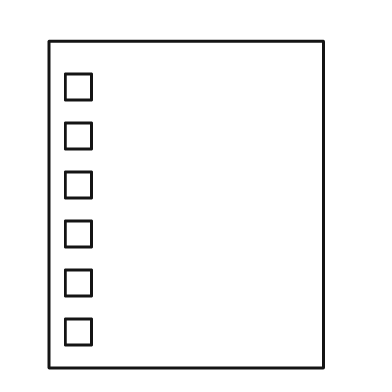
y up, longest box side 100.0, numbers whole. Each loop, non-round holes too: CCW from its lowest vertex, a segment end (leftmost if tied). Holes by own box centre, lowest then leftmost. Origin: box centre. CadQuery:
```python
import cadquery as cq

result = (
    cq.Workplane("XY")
    .moveTo(-42.0, -50.0)
    .lineTo(42.0, -50.0)
    .lineTo(42.0, 50.0)
    .lineTo(-42.0, 50.0)
    .close()
    .moveTo(-37.0, -43.0)
    .lineTo(-29.0, -43.0)
    .lineTo(-29.0, -35.0)
    .lineTo(-37.0, -35.0)
    .close()
    .moveTo(-37.0, -28.0)
    .lineTo(-29.0, -28.0)
    .lineTo(-29.0, -20.0)
    .lineTo(-37.0, -20.0)
    .close()
    .moveTo(-37.0, -13.0)
    .lineTo(-29.0, -13.0)
    .lineTo(-29.0, -5.0)
    .lineTo(-37.0, -5.0)
    .close()
    .moveTo(-37.0, 2.0)
    .lineTo(-29.0, 2.0)
    .lineTo(-29.0, 10.0)
    .lineTo(-37.0, 10.0)
    .close()
    .moveTo(-37.0, 17.0)
    .lineTo(-29.0, 17.0)
    .lineTo(-29.0, 25.0)
    .lineTo(-37.0, 25.0)
    .close()
    .moveTo(-37.0, 32.0)
    .lineTo(-29.0, 32.0)
    .lineTo(-29.0, 40.0)
    .lineTo(-37.0, 40.0)
    .close()
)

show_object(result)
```